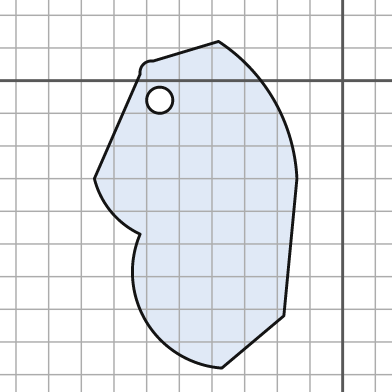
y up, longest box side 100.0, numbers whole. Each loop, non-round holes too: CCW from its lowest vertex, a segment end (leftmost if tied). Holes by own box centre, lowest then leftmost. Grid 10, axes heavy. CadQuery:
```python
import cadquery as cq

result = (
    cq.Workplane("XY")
    .moveTo(-37.0, -88.0)
    .lineTo(-18.0, -72.0)
    .lineTo(-14.0, -30.0)
    .threePointArc((-21.0, -6.0), (-38.0, 12.0))
    .lineTo(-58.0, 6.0)
    .threePointArc((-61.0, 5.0), (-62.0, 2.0))
    .lineTo(-76.0, -30.0)
    .threePointArc((-71.0, -40.0), (-62.0, -47.0))
    .threePointArc((-60.0, -74.0), (-37.0, -88.0))
    .close()
    .moveTo(-56.0, -6.0)
    .circle(4.0)
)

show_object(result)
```